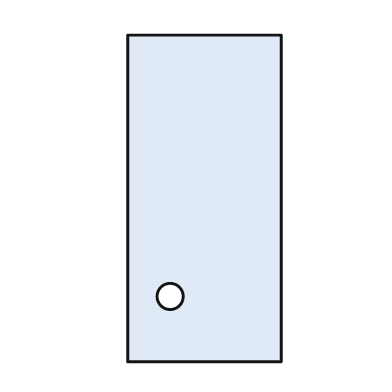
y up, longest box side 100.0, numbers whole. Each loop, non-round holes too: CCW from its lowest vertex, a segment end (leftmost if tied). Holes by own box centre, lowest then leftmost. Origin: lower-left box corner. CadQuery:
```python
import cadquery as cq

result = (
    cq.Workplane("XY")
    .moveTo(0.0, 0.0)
    .lineTo(47.0, 0.0)
    .lineTo(47.0, 100.0)
    .lineTo(0.0, 100.0)
    .close()
    .moveTo(13.0, 20.0)
    .circle(4.0)
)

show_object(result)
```